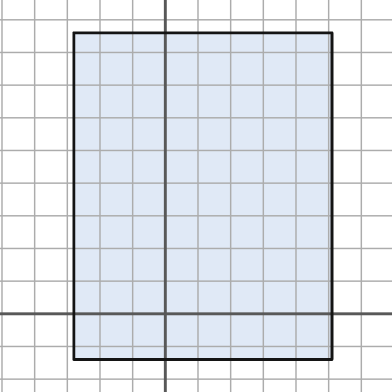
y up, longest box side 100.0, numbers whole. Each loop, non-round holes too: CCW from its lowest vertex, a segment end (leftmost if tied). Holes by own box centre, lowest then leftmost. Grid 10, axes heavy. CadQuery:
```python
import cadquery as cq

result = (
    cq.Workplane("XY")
    .moveTo(-28.0, -14.0)
    .lineTo(51.0, -14.0)
    .lineTo(51.0, 86.0)
    .lineTo(-28.0, 86.0)
    .close()
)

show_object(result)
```